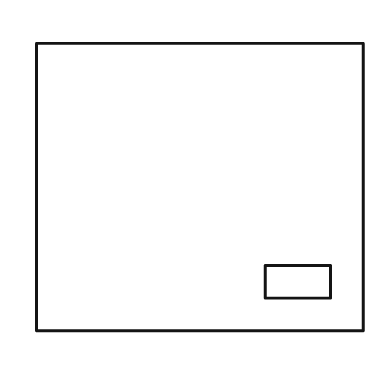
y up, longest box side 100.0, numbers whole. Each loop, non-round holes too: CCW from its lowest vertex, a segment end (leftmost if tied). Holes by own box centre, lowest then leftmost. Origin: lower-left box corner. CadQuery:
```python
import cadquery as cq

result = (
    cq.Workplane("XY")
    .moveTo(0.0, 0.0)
    .lineTo(100.0, 0.0)
    .lineTo(100.0, 88.0)
    .lineTo(0.0, 88.0)
    .close()
    .moveTo(70.0, 10.0)
    .lineTo(90.0, 10.0)
    .lineTo(90.0, 20.0)
    .lineTo(70.0, 20.0)
    .close()
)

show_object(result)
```